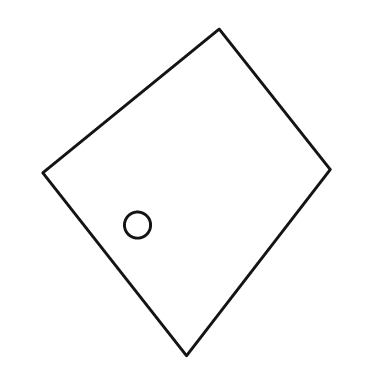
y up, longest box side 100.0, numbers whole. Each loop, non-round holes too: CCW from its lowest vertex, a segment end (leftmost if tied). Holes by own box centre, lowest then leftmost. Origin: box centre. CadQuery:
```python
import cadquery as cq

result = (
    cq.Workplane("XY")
    .moveTo(0.0, -50.0)
    .lineTo(44.0, 7.0)
    .lineTo(10.0, 50.0)
    .lineTo(-44.0, 6.0)
    .close()
    .moveTo(-15.0, -10.0)
    .circle(4.0)
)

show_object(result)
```